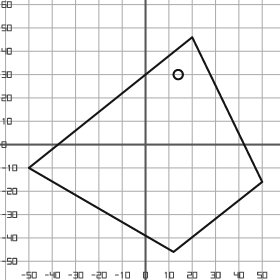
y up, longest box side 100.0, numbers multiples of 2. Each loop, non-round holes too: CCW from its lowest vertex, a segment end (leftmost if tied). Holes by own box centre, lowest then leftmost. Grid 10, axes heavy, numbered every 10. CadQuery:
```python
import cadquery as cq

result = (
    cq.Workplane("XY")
    .moveTo(12.0, -46.0)
    .lineTo(50.0, -16.0)
    .lineTo(20.0, 46.0)
    .lineTo(-50.0, -10.0)
    .close()
    .moveTo(14.0, 30.0)
    .circle(2.0)
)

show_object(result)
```